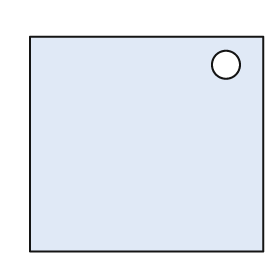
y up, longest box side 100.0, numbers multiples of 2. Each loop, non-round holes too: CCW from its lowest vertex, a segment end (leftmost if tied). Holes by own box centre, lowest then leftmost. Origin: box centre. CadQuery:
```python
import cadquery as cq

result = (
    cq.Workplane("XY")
    .moveTo(-50.0, -46.0)
    .lineTo(50.0, -46.0)
    .lineTo(50.0, 46.0)
    .lineTo(-50.0, 46.0)
    .close()
    .moveTo(34.0, 34.0)
    .circle(6.0)
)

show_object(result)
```